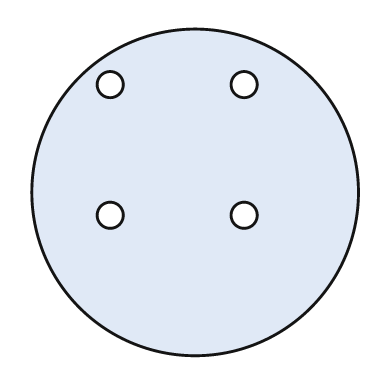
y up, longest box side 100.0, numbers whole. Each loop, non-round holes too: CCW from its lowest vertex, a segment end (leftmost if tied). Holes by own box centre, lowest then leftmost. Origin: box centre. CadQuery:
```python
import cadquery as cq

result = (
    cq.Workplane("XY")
    .moveTo(0.0, 0.0)
    .circle(50.0)
    .moveTo(-26.0, -7.0)
    .circle(4.0)
    .moveTo(15.0, -7.0)
    .circle(4.0)
    .moveTo(-26.0, 33.0)
    .circle(4.0)
    .moveTo(15.0, 33.0)
    .circle(4.0)
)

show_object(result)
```